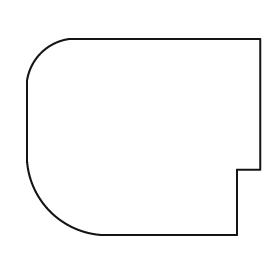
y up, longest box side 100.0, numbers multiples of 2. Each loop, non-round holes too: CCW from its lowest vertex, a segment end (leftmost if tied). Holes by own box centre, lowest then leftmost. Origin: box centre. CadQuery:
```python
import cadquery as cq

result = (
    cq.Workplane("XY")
    .moveTo(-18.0, -42.0)
    .lineTo(40.0, -42.0)
    .lineTo(40.0, -14.0)
    .lineTo(50.0, -14.0)
    .lineTo(50.0, 42.0)
    .lineTo(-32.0, 42.0)
    .threePointArc((-44.0, 36.0), (-50.0, 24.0))
    .lineTo(-50.0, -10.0)
    .threePointArc((-40.0, -32.0), (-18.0, -42.0))
    .close()
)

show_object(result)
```